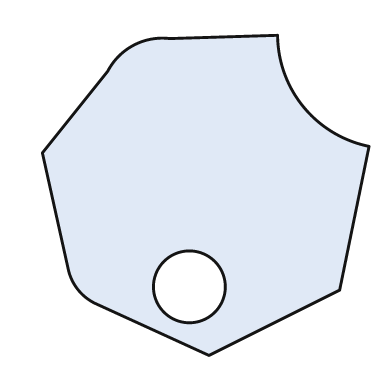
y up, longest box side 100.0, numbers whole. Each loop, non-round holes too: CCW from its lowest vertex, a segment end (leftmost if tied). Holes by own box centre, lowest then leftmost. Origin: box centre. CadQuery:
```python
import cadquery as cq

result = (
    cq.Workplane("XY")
    .moveTo(1.0, -49.0)
    .lineTo(41.0, -29.0)
    .lineTo(50.0, 15.0)
    .threePointArc((30.0, 27.0), (22.0, 49.0))
    .lineTo(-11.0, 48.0)
    .threePointArc((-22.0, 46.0), (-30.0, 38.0))
    .lineTo(-50.0, 13.0)
    .lineTo(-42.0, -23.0)
    .threePointArc((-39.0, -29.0), (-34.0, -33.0))
    .close()
    .moveTo(-5.0, -28.0)
    .circle(11.0)
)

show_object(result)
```